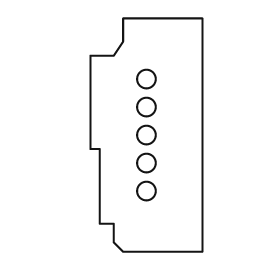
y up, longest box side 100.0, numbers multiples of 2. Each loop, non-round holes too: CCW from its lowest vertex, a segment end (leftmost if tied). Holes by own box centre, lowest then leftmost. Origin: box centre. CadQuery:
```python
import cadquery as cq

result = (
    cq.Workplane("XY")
    .moveTo(-10.0, -50.0)
    .lineTo(24.0, -50.0)
    .lineTo(24.0, 50.0)
    .lineTo(-10.0, 50.0)
    .lineTo(-10.0, 40.0)
    .lineTo(-14.0, 34.0)
    .lineTo(-24.0, 34.0)
    .lineTo(-24.0, -6.0)
    .lineTo(-20.0, -6.0)
    .lineTo(-20.0, -38.0)
    .lineTo(-14.0, -38.0)
    .lineTo(-14.0, -46.0)
    .close()
    .moveTo(0.0, -24.0)
    .circle(4.0)
    .moveTo(0.0, -12.0)
    .circle(4.0)
    .moveTo(0.0, 0.0)
    .circle(4.0)
    .moveTo(0.0, 12.0)
    .circle(4.0)
    .moveTo(0.0, 24.0)
    .circle(4.0)
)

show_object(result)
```